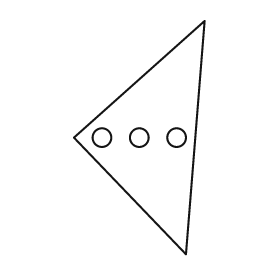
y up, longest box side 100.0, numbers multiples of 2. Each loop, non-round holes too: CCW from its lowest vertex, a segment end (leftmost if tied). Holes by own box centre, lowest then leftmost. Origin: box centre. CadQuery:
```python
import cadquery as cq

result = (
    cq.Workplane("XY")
    .moveTo(20.0, -50.0)
    .lineTo(28.0, 50.0)
    .lineTo(-28.0, 0.0)
    .close()
    .moveTo(-16.0, 0.0)
    .circle(4.0)
    .moveTo(0.0, 0.0)
    .circle(4.0)
    .moveTo(16.0, 0.0)
    .circle(4.0)
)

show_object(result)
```